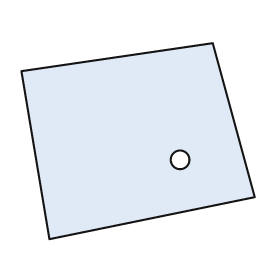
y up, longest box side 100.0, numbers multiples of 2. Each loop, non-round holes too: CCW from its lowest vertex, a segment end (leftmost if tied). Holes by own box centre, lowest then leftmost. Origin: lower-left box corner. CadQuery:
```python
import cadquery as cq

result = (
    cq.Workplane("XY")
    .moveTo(12.0, 0.0)
    .lineTo(100.0, 18.0)
    .lineTo(82.0, 84.0)
    .lineTo(0.0, 72.0)
    .close()
    .moveTo(68.0, 34.0)
    .circle(4.0)
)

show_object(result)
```